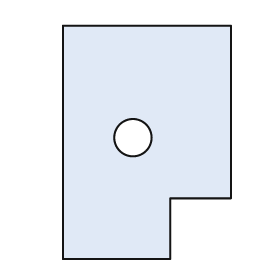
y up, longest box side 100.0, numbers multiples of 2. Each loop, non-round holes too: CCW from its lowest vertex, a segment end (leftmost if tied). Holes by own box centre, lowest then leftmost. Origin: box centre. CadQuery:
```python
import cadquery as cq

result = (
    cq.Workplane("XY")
    .moveTo(-36.0, -50.0)
    .lineTo(10.0, -50.0)
    .lineTo(10.0, -24.0)
    .lineTo(36.0, -24.0)
    .lineTo(36.0, 50.0)
    .lineTo(-36.0, 50.0)
    .close()
    .moveTo(-6.0, 2.0)
    .circle(8.0)
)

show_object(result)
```